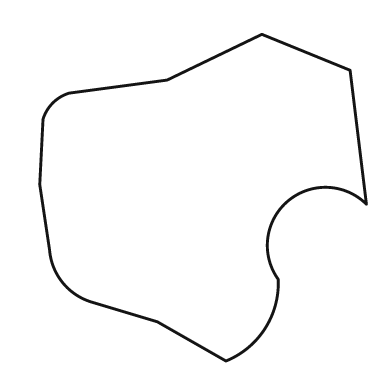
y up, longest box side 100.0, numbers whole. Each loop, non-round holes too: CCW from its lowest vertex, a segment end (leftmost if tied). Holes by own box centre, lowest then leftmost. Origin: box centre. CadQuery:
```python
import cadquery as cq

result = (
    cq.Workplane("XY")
    .moveTo(7.0, -50.0)
    .threePointArc((19.0, -40.0), (23.0, -25.0))
    .threePointArc((26.0, -1.0), (50.0, -2.0))
    .lineTo(45.0, 39.0)
    .lineTo(18.0, 50.0)
    .lineTo(-11.0, 36.0)
    .lineTo(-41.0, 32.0)
    .threePointArc((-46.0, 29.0), (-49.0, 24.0))
    .lineTo(-50.0, 4.0)
    .lineTo(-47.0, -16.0)
    .threePointArc((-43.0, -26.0), (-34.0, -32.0))
    .lineTo(-14.0, -38.0)
    .close()
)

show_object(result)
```